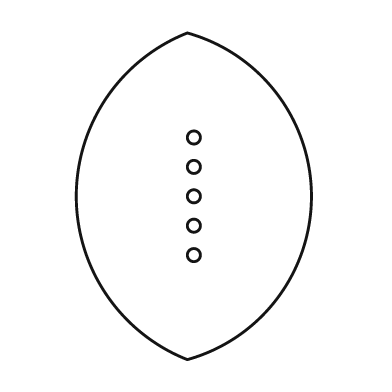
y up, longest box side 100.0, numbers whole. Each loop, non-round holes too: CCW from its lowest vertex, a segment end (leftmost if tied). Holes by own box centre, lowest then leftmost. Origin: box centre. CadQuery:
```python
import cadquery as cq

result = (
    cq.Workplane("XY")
    .moveTo(-2.0, -50.0)
    .threePointArc((36.0, 0.0), (-2.0, 50.0))
    .threePointArc((-36.0, 0.0), (-2.0, -50.0))
    .close()
    .moveTo(0.0, -18.0)
    .circle(2.0)
    .moveTo(0.0, -9.0)
    .circle(2.0)
    .moveTo(0.0, 0.0)
    .circle(2.0)
    .moveTo(0.0, 9.0)
    .circle(2.0)
    .moveTo(0.0, 18.0)
    .circle(2.0)
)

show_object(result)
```